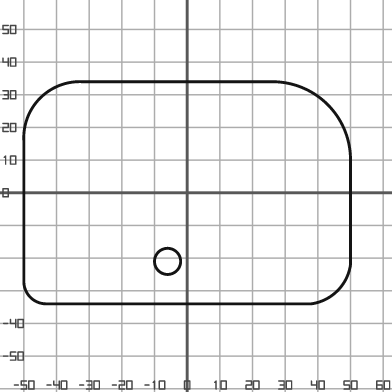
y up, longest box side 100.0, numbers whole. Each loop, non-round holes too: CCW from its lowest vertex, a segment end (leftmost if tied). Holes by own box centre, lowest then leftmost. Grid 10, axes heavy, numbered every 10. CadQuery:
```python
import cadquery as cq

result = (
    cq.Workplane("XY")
    .moveTo(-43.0, -34.0)
    .lineTo(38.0, -34.0)
    .threePointArc((46.0, -30.0), (50.0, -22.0))
    .lineTo(50.0, 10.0)
    .threePointArc((43.0, 27.0), (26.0, 34.0))
    .lineTo(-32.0, 34.0)
    .threePointArc((-45.0, 29.0), (-50.0, 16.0))
    .lineTo(-50.0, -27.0)
    .threePointArc((-48.0, -32.0), (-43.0, -34.0))
    .close()
    .moveTo(-6.0, -21.0)
    .circle(4.0)
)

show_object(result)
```